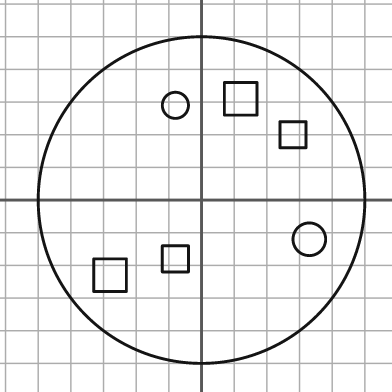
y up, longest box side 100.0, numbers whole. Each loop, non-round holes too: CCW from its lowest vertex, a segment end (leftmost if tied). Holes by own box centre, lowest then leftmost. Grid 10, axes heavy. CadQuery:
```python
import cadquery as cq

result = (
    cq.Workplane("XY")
    .moveTo(0.0, 0.0)
    .circle(50.0)
    .moveTo(-33.0, -28.0)
    .lineTo(-23.0, -28.0)
    .lineTo(-23.0, -18.0)
    .lineTo(-33.0, -18.0)
    .close()
    .moveTo(-12.0, -22.0)
    .lineTo(-4.0, -22.0)
    .lineTo(-4.0, -14.0)
    .lineTo(-12.0, -14.0)
    .close()
    .moveTo(33.0, -12.0)
    .circle(5.0)
    .moveTo(24.0, 16.0)
    .lineTo(32.0, 16.0)
    .lineTo(32.0, 24.0)
    .lineTo(24.0, 24.0)
    .close()
    .moveTo(-8.0, 29.0)
    .circle(4.0)
    .moveTo(7.0, 26.0)
    .lineTo(17.0, 26.0)
    .lineTo(17.0, 36.0)
    .lineTo(7.0, 36.0)
    .close()
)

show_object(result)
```